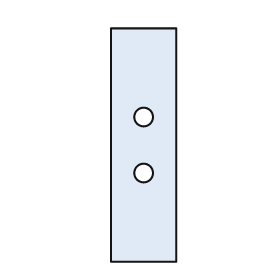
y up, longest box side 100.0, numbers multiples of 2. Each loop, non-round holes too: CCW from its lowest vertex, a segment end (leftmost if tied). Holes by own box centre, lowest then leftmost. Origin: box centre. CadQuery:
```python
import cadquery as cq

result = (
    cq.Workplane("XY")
    .moveTo(-14.0, -50.0)
    .lineTo(14.0, -50.0)
    .lineTo(14.0, 50.0)
    .lineTo(-14.0, 50.0)
    .close()
    .moveTo(0.0, -12.0)
    .circle(4.0)
    .moveTo(0.0, 12.0)
    .circle(4.0)
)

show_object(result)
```